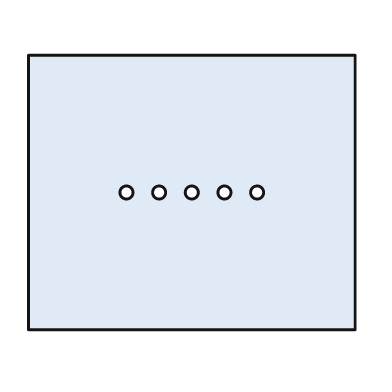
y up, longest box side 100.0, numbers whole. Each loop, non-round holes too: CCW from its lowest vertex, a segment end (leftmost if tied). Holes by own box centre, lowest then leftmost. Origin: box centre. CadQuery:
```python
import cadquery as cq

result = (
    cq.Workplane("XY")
    .moveTo(-50.0, -42.0)
    .lineTo(50.0, -42.0)
    .lineTo(50.0, 42.0)
    .lineTo(-50.0, 42.0)
    .close()
    .moveTo(-20.0, 0.0)
    .circle(2.0)
    .moveTo(-10.0, 0.0)
    .circle(2.0)
    .moveTo(0.0, 0.0)
    .circle(2.0)
    .moveTo(10.0, 0.0)
    .circle(2.0)
    .moveTo(20.0, 0.0)
    .circle(2.0)
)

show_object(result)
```